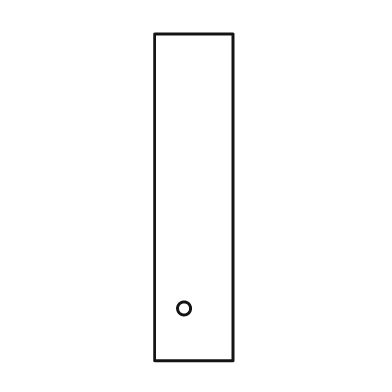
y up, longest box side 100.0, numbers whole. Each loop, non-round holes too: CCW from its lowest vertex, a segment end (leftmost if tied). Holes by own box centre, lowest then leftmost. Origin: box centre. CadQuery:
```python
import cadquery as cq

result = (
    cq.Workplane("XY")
    .moveTo(-12.0, -50.0)
    .lineTo(12.0, -50.0)
    .lineTo(12.0, 50.0)
    .lineTo(-12.0, 50.0)
    .close()
    .moveTo(-3.0, -34.0)
    .circle(2.0)
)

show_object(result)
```